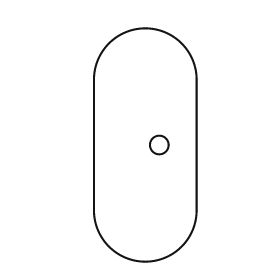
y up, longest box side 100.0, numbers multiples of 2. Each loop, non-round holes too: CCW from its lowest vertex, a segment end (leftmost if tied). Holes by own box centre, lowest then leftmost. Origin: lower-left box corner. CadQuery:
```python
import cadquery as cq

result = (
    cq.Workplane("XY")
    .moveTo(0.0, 22.0)
    .threePointArc((22.0, 0.0), (44.0, 22.0))
    .lineTo(44.0, 78.0)
    .threePointArc((22.0, 100.0), (0.0, 78.0))
    .close()
    .moveTo(28.0, 50.0)
    .circle(4.0)
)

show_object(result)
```